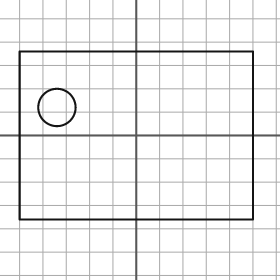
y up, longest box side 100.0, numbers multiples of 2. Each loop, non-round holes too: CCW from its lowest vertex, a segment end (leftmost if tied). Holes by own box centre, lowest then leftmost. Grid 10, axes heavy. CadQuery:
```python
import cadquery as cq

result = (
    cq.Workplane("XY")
    .moveTo(-50.0, -36.0)
    .lineTo(50.0, -36.0)
    .lineTo(50.0, 36.0)
    .lineTo(-50.0, 36.0)
    .close()
    .moveTo(-34.0, 12.0)
    .circle(8.0)
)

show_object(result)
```